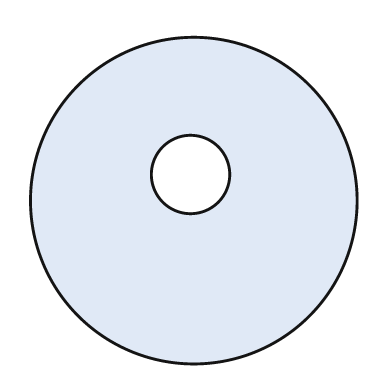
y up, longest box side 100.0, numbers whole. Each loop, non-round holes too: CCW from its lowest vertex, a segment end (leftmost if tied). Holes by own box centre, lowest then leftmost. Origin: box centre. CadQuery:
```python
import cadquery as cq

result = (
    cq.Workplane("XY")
    .moveTo(0.0, 0.0)
    .circle(50.0)
    .moveTo(-1.0, 8.0)
    .circle(12.0)
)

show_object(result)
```